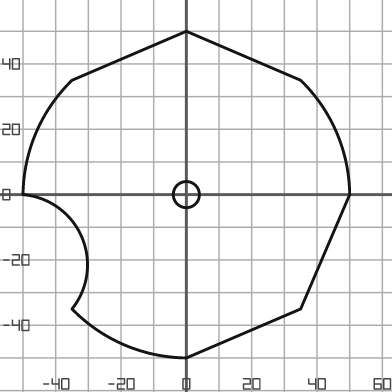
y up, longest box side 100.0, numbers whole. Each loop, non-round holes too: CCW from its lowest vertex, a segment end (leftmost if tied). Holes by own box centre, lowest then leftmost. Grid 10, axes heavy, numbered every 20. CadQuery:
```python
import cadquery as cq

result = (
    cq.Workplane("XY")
    .moveTo(0.0, -50.0)
    .lineTo(35.0, -35.0)
    .lineTo(50.0, 0.0)
    .threePointArc((46.0, 19.0), (35.0, 35.0))
    .lineTo(0.0, 50.0)
    .lineTo(-35.0, 35.0)
    .threePointArc((-46.0, 19.0), (-50.0, 0.0))
    .threePointArc((-32.0, -13.0), (-35.0, -35.0))
    .threePointArc((-19.0, -46.0), (0.0, -50.0))
    .close()
    .moveTo(0.0, 0.0)
    .circle(4.0)
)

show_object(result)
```